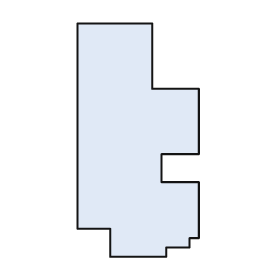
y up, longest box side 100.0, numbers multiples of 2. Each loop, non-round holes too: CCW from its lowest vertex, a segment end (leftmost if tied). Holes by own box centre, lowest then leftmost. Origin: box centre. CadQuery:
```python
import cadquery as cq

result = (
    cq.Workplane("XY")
    .moveTo(-12.0, -50.0)
    .lineTo(12.0, -50.0)
    .lineTo(12.0, -46.0)
    .lineTo(22.0, -46.0)
    .lineTo(22.0, -42.0)
    .lineTo(26.0, -42.0)
    .lineTo(26.0, -18.0)
    .lineTo(10.0, -18.0)
    .lineTo(10.0, -6.0)
    .lineTo(26.0, -6.0)
    .lineTo(26.0, 22.0)
    .lineTo(6.0, 22.0)
    .lineTo(6.0, 50.0)
    .lineTo(-26.0, 50.0)
    .lineTo(-26.0, -38.0)
    .lineTo(-12.0, -38.0)
    .close()
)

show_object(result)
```